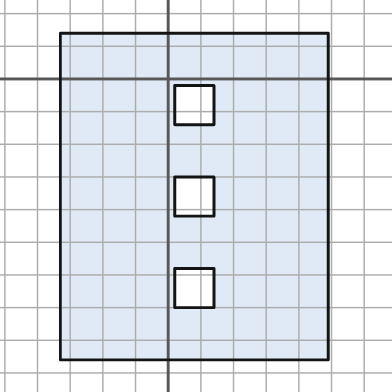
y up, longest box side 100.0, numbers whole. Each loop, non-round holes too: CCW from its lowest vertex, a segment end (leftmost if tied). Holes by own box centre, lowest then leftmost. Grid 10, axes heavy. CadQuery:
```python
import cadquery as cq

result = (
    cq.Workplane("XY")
    .moveTo(-33.0, -86.0)
    .lineTo(49.0, -86.0)
    .lineTo(49.0, 14.0)
    .lineTo(-33.0, 14.0)
    .close()
    .moveTo(2.0, -70.0)
    .lineTo(14.0, -70.0)
    .lineTo(14.0, -58.0)
    .lineTo(2.0, -58.0)
    .close()
    .moveTo(2.0, -42.0)
    .lineTo(14.0, -42.0)
    .lineTo(14.0, -30.0)
    .lineTo(2.0, -30.0)
    .close()
    .moveTo(2.0, -14.0)
    .lineTo(14.0, -14.0)
    .lineTo(14.0, -2.0)
    .lineTo(2.0, -2.0)
    .close()
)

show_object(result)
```